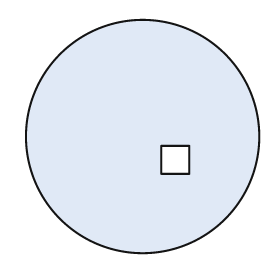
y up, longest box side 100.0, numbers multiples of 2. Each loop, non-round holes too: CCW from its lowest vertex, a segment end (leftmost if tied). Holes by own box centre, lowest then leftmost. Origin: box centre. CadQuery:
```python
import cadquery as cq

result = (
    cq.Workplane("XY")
    .moveTo(0.0, 0.0)
    .circle(50.0)
    .moveTo(8.0, -16.0)
    .lineTo(20.0, -16.0)
    .lineTo(20.0, -4.0)
    .lineTo(8.0, -4.0)
    .close()
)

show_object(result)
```